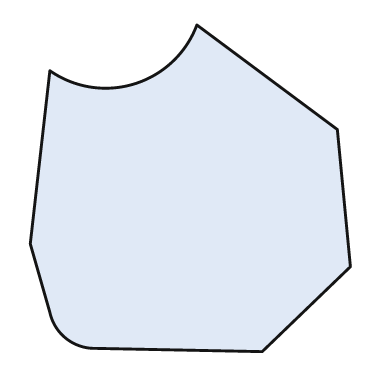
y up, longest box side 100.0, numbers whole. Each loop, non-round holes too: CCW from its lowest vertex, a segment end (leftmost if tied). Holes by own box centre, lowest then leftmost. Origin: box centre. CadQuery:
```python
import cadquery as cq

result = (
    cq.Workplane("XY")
    .moveTo(22.0, -50.0)
    .lineTo(49.0, -24.0)
    .lineTo(45.0, 18.0)
    .lineTo(2.0, 50.0)
    .threePointArc((-17.0, 32.0), (-43.0, 36.0))
    .lineTo(-49.0, -17.0)
    .lineTo(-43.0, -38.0)
    .threePointArc((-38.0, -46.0), (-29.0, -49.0))
    .close()
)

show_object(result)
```